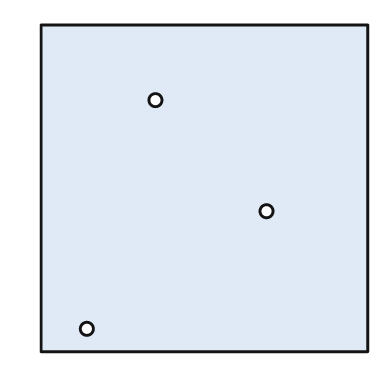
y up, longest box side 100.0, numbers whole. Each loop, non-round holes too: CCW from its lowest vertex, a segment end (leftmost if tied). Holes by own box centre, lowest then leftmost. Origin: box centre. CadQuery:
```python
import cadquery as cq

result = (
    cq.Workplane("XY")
    .moveTo(-50.0, -50.0)
    .lineTo(50.0, -50.0)
    .lineTo(50.0, 50.0)
    .lineTo(-50.0, 50.0)
    .close()
    .moveTo(-36.0, -43.0)
    .circle(2.0)
    .moveTo(19.0, -7.0)
    .circle(2.0)
    .moveTo(-15.0, 27.0)
    .circle(2.0)
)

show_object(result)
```